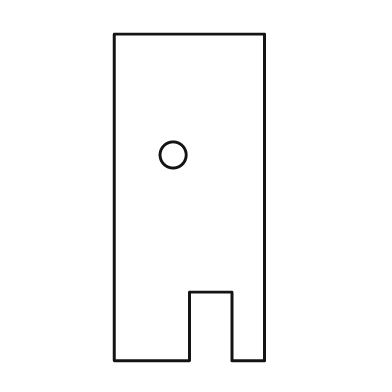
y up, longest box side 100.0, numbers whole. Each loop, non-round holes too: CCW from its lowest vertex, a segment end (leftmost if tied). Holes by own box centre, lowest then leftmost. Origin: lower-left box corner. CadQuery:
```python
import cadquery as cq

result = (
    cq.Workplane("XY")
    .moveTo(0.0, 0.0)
    .lineTo(23.0, 0.0)
    .lineTo(23.0, 21.0)
    .lineTo(36.0, 21.0)
    .lineTo(36.0, 0.0)
    .lineTo(46.0, 0.0)
    .lineTo(46.0, 100.0)
    .lineTo(0.0, 100.0)
    .close()
    .moveTo(18.0, 63.0)
    .circle(4.0)
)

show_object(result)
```